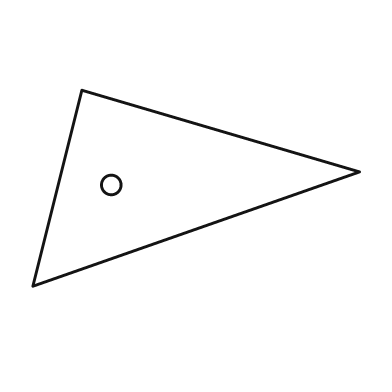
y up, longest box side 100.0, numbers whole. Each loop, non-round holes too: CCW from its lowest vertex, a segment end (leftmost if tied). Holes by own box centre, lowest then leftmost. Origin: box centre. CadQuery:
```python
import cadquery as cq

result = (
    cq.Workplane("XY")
    .moveTo(-50.0, -30.0)
    .lineTo(50.0, 5.0)
    .lineTo(-35.0, 30.0)
    .close()
    .moveTo(-26.0, 1.0)
    .circle(3.0)
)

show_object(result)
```